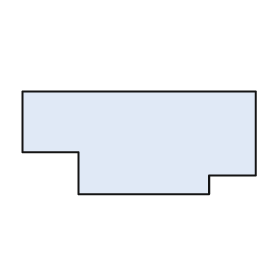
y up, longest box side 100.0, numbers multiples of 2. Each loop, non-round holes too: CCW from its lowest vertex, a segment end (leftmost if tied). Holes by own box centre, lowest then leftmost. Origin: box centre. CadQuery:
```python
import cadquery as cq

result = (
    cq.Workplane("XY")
    .moveTo(-26.0, -22.0)
    .lineTo(30.0, -22.0)
    .lineTo(30.0, -14.0)
    .lineTo(50.0, -14.0)
    .lineTo(50.0, 22.0)
    .lineTo(-50.0, 22.0)
    .lineTo(-50.0, -4.0)
    .lineTo(-26.0, -4.0)
    .close()
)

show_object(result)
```